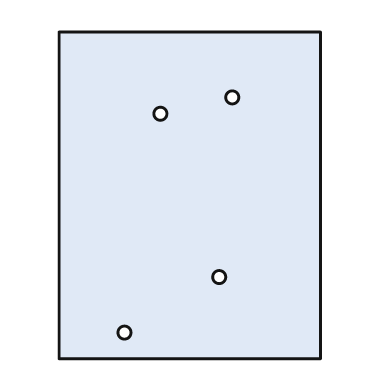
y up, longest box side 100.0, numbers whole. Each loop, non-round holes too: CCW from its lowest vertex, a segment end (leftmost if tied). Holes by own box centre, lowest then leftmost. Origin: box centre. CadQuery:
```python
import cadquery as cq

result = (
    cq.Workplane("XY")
    .moveTo(-40.0, -50.0)
    .lineTo(40.0, -50.0)
    .lineTo(40.0, 50.0)
    .lineTo(-40.0, 50.0)
    .close()
    .moveTo(-20.0, -42.0)
    .circle(2.0)
    .moveTo(9.0, -25.0)
    .circle(2.0)
    .moveTo(-9.0, 25.0)
    .circle(2.0)
    .moveTo(13.0, 30.0)
    .circle(2.0)
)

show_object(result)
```